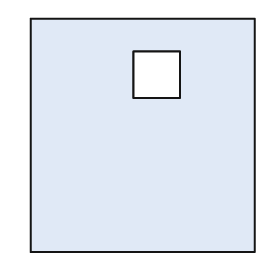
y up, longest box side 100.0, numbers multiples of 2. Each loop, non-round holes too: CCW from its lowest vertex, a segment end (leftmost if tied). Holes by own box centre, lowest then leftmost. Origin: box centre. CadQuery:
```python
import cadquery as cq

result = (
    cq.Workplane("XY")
    .moveTo(-48.0, -50.0)
    .lineTo(48.0, -50.0)
    .lineTo(48.0, 50.0)
    .lineTo(-48.0, 50.0)
    .close()
    .moveTo(-4.0, 16.0)
    .lineTo(16.0, 16.0)
    .lineTo(16.0, 36.0)
    .lineTo(-4.0, 36.0)
    .close()
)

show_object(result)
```